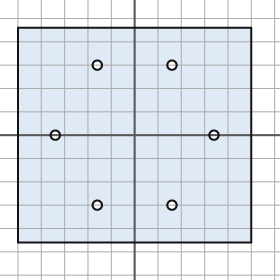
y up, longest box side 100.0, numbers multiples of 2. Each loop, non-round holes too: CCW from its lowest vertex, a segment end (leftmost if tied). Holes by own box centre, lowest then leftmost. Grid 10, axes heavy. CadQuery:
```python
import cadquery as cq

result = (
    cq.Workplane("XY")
    .moveTo(-50.0, -46.0)
    .lineTo(50.0, -46.0)
    .lineTo(50.0, 46.0)
    .lineTo(-50.0, 46.0)
    .close()
    .moveTo(-16.0, -30.0)
    .circle(2.0)
    .moveTo(16.0, -30.0)
    .circle(2.0)
    .moveTo(-34.0, 0.0)
    .circle(2.0)
    .moveTo(34.0, 0.0)
    .circle(2.0)
    .moveTo(-16.0, 30.0)
    .circle(2.0)
    .moveTo(16.0, 30.0)
    .circle(2.0)
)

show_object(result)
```